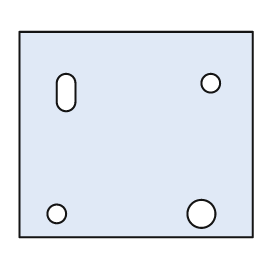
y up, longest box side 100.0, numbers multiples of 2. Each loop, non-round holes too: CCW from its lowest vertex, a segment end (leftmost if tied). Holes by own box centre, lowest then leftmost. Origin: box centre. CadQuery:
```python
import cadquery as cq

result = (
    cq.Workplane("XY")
    .moveTo(-50.0, -44.0)
    .lineTo(50.0, -44.0)
    .lineTo(50.0, 44.0)
    .lineTo(-50.0, 44.0)
    .close()
    .moveTo(-34.0, -34.0)
    .circle(4.0)
    .moveTo(28.0, -34.0)
    .circle(6.0)
    .moveTo(-34.0, 14.0)
    .threePointArc((-30.0, 10.0), (-26.0, 14.0))
    .lineTo(-26.0, 22.0)
    .threePointArc((-30.0, 26.0), (-34.0, 22.0))
    .close()
    .moveTo(32.0, 22.0)
    .circle(4.0)
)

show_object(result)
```